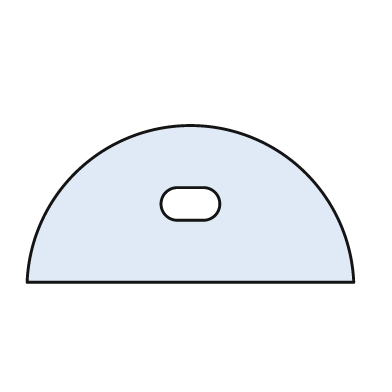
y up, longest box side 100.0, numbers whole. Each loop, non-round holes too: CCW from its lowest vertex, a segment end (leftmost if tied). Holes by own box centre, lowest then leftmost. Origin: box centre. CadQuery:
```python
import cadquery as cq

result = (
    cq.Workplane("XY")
    .moveTo(-50.0, -24.0)
    .lineTo(50.0, -24.0)
    .threePointArc((0.0, 24.0), (-50.0, -24.0))
    .close()
    .moveTo(-4.0, -5.0)
    .lineTo(4.0, -5.0)
    .threePointArc((9.0, 0.0), (4.0, 5.0))
    .lineTo(-4.0, 5.0)
    .threePointArc((-9.0, 0.0), (-4.0, -5.0))
    .close()
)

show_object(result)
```